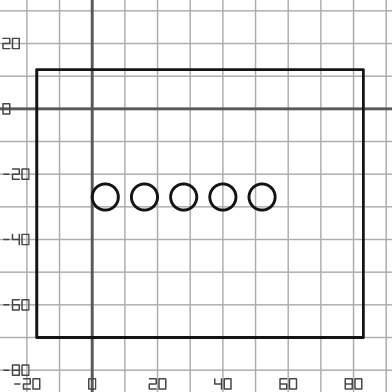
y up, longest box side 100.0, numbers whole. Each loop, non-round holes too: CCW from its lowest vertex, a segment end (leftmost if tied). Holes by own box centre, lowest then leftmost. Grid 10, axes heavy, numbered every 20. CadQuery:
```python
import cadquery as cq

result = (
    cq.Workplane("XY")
    .moveTo(-17.0, -70.0)
    .lineTo(83.0, -70.0)
    .lineTo(83.0, 12.0)
    .lineTo(-17.0, 12.0)
    .close()
    .moveTo(4.0, -27.0)
    .circle(4.0)
    .moveTo(16.0, -27.0)
    .circle(4.0)
    .moveTo(28.0, -27.0)
    .circle(4.0)
    .moveTo(40.0, -27.0)
    .circle(4.0)
    .moveTo(52.0, -27.0)
    .circle(4.0)
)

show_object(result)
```